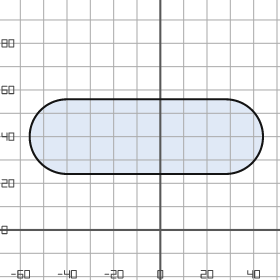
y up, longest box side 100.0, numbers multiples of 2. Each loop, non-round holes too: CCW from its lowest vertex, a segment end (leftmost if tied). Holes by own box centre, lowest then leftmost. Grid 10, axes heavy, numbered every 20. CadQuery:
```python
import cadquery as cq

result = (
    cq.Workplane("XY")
    .moveTo(-40.0, 24.0)
    .lineTo(28.0, 24.0)
    .threePointArc((44.0, 40.0), (28.0, 56.0))
    .lineTo(-40.0, 56.0)
    .threePointArc((-56.0, 40.0), (-40.0, 24.0))
    .close()
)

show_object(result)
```